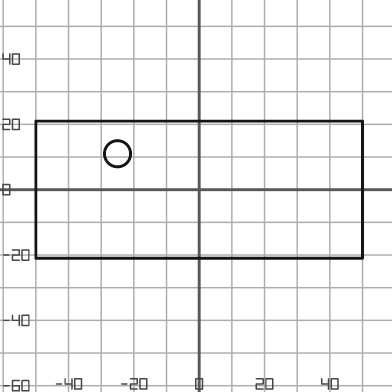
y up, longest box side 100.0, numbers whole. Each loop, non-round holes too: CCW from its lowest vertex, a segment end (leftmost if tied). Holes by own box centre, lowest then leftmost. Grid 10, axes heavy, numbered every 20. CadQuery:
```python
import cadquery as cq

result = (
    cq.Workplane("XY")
    .moveTo(-50.0, -21.0)
    .lineTo(50.0, -21.0)
    .lineTo(50.0, 21.0)
    .lineTo(-50.0, 21.0)
    .close()
    .moveTo(-25.0, 11.0)
    .circle(4.0)
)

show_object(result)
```